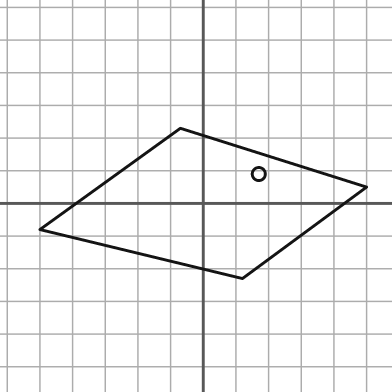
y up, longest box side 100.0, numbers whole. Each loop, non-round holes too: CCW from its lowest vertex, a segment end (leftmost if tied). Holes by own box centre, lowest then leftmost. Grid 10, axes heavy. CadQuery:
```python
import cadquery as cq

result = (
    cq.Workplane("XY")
    .moveTo(12.0, -23.0)
    .lineTo(50.0, 5.0)
    .lineTo(-7.0, 23.0)
    .lineTo(-50.0, -8.0)
    .close()
    .moveTo(17.0, 9.0)
    .circle(2.0)
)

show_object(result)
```